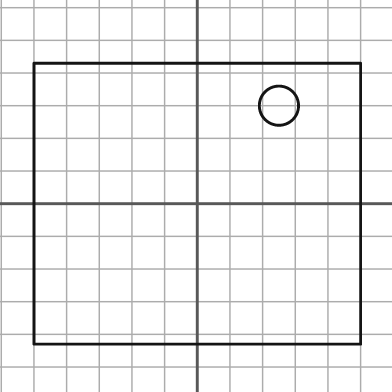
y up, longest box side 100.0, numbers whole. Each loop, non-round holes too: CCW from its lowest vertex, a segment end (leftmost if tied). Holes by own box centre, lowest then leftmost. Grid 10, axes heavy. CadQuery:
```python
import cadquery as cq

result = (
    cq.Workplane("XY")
    .moveTo(-50.0, -43.0)
    .lineTo(50.0, -43.0)
    .lineTo(50.0, 43.0)
    .lineTo(-50.0, 43.0)
    .close()
    .moveTo(25.0, 30.0)
    .circle(6.0)
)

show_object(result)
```